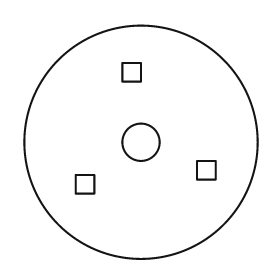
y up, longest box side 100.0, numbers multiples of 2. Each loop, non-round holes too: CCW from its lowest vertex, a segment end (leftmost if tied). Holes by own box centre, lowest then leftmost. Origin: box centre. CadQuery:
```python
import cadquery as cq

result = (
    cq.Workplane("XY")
    .moveTo(0.0, 0.0)
    .circle(50.0)
    .moveTo(-28.0, -22.0)
    .lineTo(-20.0, -22.0)
    .lineTo(-20.0, -14.0)
    .lineTo(-28.0, -14.0)
    .close()
    .moveTo(24.0, -16.0)
    .lineTo(32.0, -16.0)
    .lineTo(32.0, -8.0)
    .lineTo(24.0, -8.0)
    .close()
    .moveTo(0.0, 0.0)
    .circle(8.0)
    .moveTo(-8.0, 26.0)
    .lineTo(0.0, 26.0)
    .lineTo(0.0, 34.0)
    .lineTo(-8.0, 34.0)
    .close()
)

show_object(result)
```